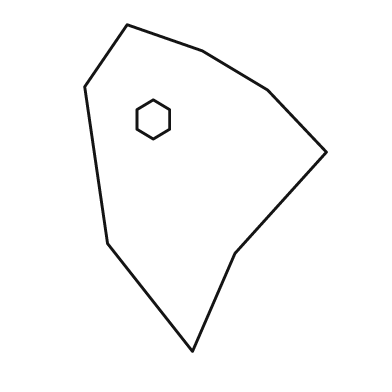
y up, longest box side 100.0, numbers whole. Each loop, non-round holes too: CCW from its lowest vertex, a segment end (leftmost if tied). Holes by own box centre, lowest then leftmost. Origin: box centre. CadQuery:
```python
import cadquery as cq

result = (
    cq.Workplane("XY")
    .moveTo(-4.0, -50.0)
    .lineTo(9.0, -20.0)
    .lineTo(37.0, 11.0)
    .lineTo(19.0, 30.0)
    .lineTo(-1.0, 42.0)
    .lineTo(-24.0, 50.0)
    .lineTo(-37.0, 31.0)
    .lineTo(-30.0, -17.0)
    .close()
    .moveTo(-16.0, 15.0)
    .lineTo(-11.0, 18.0)
    .lineTo(-11.0, 24.0)
    .lineTo(-16.0, 27.0)
    .lineTo(-21.0, 24.0)
    .lineTo(-21.0, 18.0)
    .close()
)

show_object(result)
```